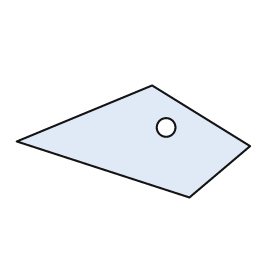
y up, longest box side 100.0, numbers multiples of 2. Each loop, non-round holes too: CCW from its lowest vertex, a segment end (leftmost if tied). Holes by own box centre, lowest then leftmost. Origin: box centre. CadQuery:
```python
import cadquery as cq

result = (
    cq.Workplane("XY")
    .moveTo(24.0, -24.0)
    .lineTo(50.0, -2.0)
    .lineTo(8.0, 24.0)
    .lineTo(-50.0, 0.0)
    .close()
    .moveTo(14.0, 6.0)
    .circle(4.0)
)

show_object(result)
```